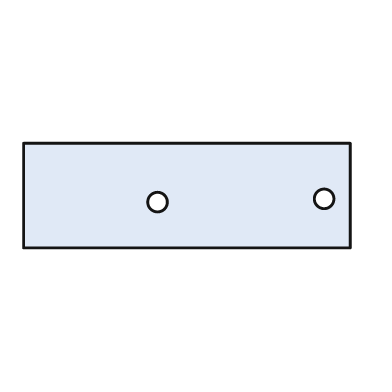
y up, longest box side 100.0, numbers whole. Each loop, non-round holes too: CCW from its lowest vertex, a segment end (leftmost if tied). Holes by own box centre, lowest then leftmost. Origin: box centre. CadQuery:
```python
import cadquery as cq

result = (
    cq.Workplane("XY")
    .moveTo(-50.0, -16.0)
    .lineTo(50.0, -16.0)
    .lineTo(50.0, 16.0)
    .lineTo(-50.0, 16.0)
    .close()
    .moveTo(-9.0, -2.0)
    .circle(3.0)
    .moveTo(42.0, -1.0)
    .circle(3.0)
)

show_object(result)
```